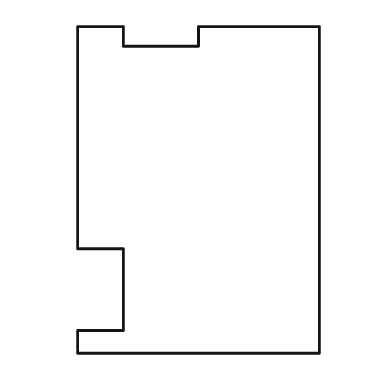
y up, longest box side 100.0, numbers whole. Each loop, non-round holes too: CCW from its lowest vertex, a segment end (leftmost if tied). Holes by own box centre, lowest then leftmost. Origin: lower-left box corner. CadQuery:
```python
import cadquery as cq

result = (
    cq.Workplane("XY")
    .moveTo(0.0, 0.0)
    .lineTo(74.0, 0.0)
    .lineTo(74.0, 100.0)
    .lineTo(37.0, 100.0)
    .lineTo(37.0, 94.0)
    .lineTo(14.0, 94.0)
    .lineTo(14.0, 100.0)
    .lineTo(0.0, 100.0)
    .lineTo(0.0, 32.0)
    .lineTo(14.0, 32.0)
    .lineTo(14.0, 7.0)
    .lineTo(0.0, 7.0)
    .close()
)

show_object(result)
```